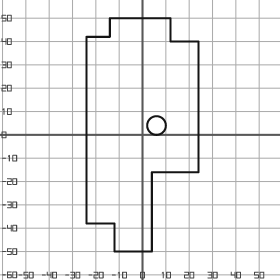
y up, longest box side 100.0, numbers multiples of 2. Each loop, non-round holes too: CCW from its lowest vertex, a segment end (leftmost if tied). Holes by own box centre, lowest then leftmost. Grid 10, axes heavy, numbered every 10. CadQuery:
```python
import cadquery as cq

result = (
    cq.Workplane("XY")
    .moveTo(-12.0, -50.0)
    .lineTo(4.0, -50.0)
    .lineTo(4.0, -16.0)
    .lineTo(24.0, -16.0)
    .lineTo(24.0, 40.0)
    .lineTo(12.0, 40.0)
    .lineTo(12.0, 50.0)
    .lineTo(-14.0, 50.0)
    .lineTo(-14.0, 42.0)
    .lineTo(-24.0, 42.0)
    .lineTo(-24.0, -38.0)
    .lineTo(-12.0, -38.0)
    .close()
    .moveTo(6.0, 4.0)
    .circle(4.0)
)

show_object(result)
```